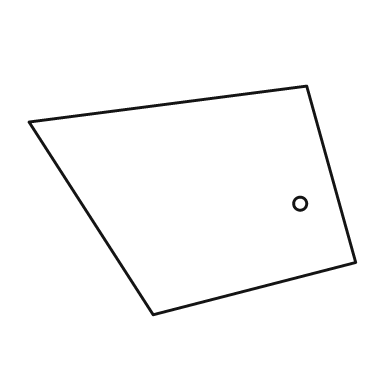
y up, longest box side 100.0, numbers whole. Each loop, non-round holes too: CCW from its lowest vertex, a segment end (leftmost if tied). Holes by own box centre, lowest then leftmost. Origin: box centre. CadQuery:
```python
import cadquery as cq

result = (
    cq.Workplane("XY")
    .moveTo(-12.0, -35.0)
    .lineTo(50.0, -19.0)
    .lineTo(35.0, 35.0)
    .lineTo(-50.0, 24.0)
    .close()
    .moveTo(33.0, -1.0)
    .circle(2.0)
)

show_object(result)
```